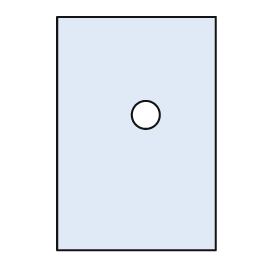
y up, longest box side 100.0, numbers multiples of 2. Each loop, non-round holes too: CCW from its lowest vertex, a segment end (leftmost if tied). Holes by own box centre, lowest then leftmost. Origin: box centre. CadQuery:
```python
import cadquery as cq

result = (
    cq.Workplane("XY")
    .moveTo(-34.0, -50.0)
    .lineTo(34.0, -50.0)
    .lineTo(34.0, 50.0)
    .lineTo(-34.0, 50.0)
    .close()
    .moveTo(4.0, 8.0)
    .circle(6.0)
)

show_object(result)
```